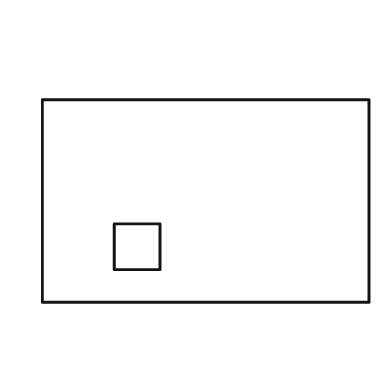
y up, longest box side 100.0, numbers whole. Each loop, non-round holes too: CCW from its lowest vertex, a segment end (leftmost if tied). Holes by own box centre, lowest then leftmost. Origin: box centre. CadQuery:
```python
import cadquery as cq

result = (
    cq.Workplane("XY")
    .moveTo(-50.0, -31.0)
    .lineTo(50.0, -31.0)
    .lineTo(50.0, 31.0)
    .lineTo(-50.0, 31.0)
    .close()
    .moveTo(-28.0, -21.0)
    .lineTo(-14.0, -21.0)
    .lineTo(-14.0, -7.0)
    .lineTo(-28.0, -7.0)
    .close()
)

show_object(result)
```